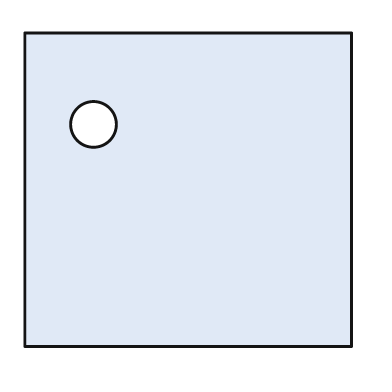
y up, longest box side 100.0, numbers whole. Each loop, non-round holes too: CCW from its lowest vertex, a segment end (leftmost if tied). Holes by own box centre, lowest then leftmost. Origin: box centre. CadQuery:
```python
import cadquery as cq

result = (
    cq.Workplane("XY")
    .moveTo(-50.0, -48.0)
    .lineTo(50.0, -48.0)
    .lineTo(50.0, 48.0)
    .lineTo(-50.0, 48.0)
    .close()
    .moveTo(-29.0, 20.0)
    .circle(7.0)
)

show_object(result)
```